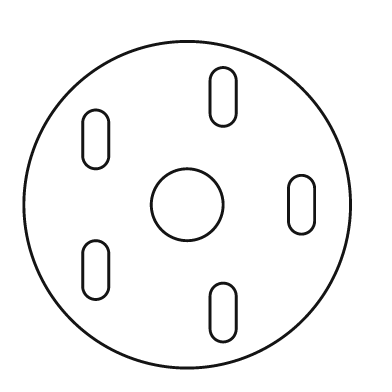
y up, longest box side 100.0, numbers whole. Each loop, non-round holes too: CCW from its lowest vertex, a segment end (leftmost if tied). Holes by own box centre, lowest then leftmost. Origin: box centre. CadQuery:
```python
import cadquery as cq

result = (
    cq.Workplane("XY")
    .moveTo(0.0, 0.0)
    .circle(50.0)
    .moveTo(7.0, -38.0)
    .threePointArc((11.0, -42.0), (15.0, -38.0))
    .lineTo(15.0, -28.0)
    .threePointArc((11.0, -24.0), (7.0, -28.0))
    .close()
    .moveTo(-32.0, -25.0)
    .threePointArc((-28.0, -29.0), (-24.0, -25.0))
    .lineTo(-24.0, -15.0)
    .threePointArc((-28.0, -11.0), (-32.0, -15.0))
    .close()
    .moveTo(0.0, 0.0)
    .circle(11.0)
    .moveTo(31.0, -5.0)
    .threePointArc((35.0, -9.0), (39.0, -5.0))
    .lineTo(39.0, 5.0)
    .threePointArc((35.0, 9.0), (31.0, 5.0))
    .close()
    .moveTo(-32.0, 15.0)
    .threePointArc((-28.0, 11.0), (-24.0, 15.0))
    .lineTo(-24.0, 25.0)
    .threePointArc((-28.0, 29.0), (-32.0, 25.0))
    .close()
    .moveTo(7.0, 28.0)
    .threePointArc((11.0, 24.0), (15.0, 28.0))
    .lineTo(15.0, 38.0)
    .threePointArc((11.0, 42.0), (7.0, 38.0))
    .close()
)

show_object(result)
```